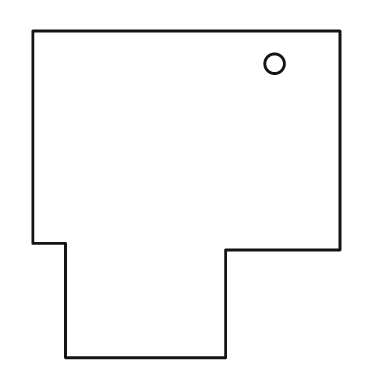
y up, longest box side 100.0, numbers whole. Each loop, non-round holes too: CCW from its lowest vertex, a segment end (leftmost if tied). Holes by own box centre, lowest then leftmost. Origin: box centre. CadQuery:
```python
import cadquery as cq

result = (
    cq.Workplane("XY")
    .moveTo(-37.0, -50.0)
    .lineTo(12.0, -50.0)
    .lineTo(12.0, -17.0)
    .lineTo(47.0, -17.0)
    .lineTo(47.0, 50.0)
    .lineTo(-47.0, 50.0)
    .lineTo(-47.0, -15.0)
    .lineTo(-37.0, -15.0)
    .close()
    .moveTo(27.0, 40.0)
    .circle(3.0)
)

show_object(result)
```